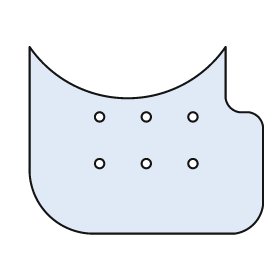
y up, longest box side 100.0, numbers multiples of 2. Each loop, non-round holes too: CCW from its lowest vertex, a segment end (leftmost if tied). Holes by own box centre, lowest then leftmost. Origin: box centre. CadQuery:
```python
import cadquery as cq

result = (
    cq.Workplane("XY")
    .moveTo(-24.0, -40.0)
    .lineTo(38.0, -40.0)
    .threePointArc((46.0, -36.0), (50.0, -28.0))
    .lineTo(50.0, 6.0)
    .threePointArc((48.0, 10.0), (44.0, 12.0))
    .lineTo(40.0, 12.0)
    .threePointArc((36.0, 14.0), (34.0, 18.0))
    .lineTo(34.0, 40.0)
    .threePointArc((-8.0, 18.0), (-50.0, 40.0))
    .lineTo(-50.0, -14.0)
    .threePointArc((-42.0, -32.0), (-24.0, -40.0))
    .close()
    .moveTo(-20.0, -10.0)
    .circle(2.0)
    .moveTo(0.0, -10.0)
    .circle(2.0)
    .moveTo(20.0, -10.0)
    .circle(2.0)
    .moveTo(-20.0, 10.0)
    .circle(2.0)
    .moveTo(0.0, 10.0)
    .circle(2.0)
    .moveTo(20.0, 10.0)
    .circle(2.0)
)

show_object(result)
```